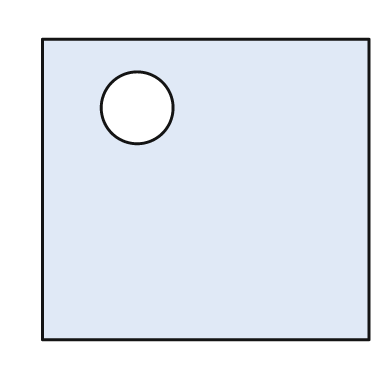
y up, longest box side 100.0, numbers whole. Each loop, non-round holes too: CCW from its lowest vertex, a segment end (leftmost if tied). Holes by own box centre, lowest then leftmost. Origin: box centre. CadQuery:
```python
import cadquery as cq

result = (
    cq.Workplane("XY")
    .moveTo(-50.0, -46.0)
    .lineTo(50.0, -46.0)
    .lineTo(50.0, 46.0)
    .lineTo(-50.0, 46.0)
    .close()
    .moveTo(-21.0, 25.0)
    .circle(11.0)
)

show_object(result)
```